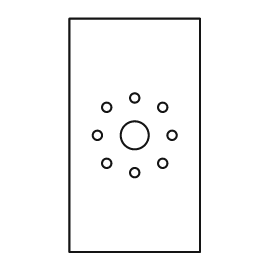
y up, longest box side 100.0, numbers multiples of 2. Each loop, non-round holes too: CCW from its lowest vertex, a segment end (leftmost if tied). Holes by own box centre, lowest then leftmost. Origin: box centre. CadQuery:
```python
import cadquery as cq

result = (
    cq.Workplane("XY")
    .moveTo(-28.0, -50.0)
    .lineTo(28.0, -50.0)
    .lineTo(28.0, 50.0)
    .lineTo(-28.0, 50.0)
    .close()
    .moveTo(0.0, -16.0)
    .circle(2.0)
    .moveTo(-12.0, -12.0)
    .circle(2.0)
    .moveTo(12.0, -12.0)
    .circle(2.0)
    .moveTo(-16.0, 0.0)
    .circle(2.0)
    .moveTo(0.0, 0.0)
    .circle(6.0)
    .moveTo(16.0, 0.0)
    .circle(2.0)
    .moveTo(-12.0, 12.0)
    .circle(2.0)
    .moveTo(12.0, 12.0)
    .circle(2.0)
    .moveTo(0.0, 16.0)
    .circle(2.0)
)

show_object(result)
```